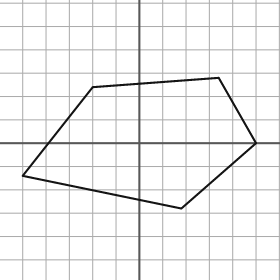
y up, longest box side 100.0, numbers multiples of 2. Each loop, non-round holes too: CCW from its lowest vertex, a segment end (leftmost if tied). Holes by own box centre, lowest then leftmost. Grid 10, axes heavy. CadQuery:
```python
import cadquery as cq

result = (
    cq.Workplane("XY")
    .moveTo(18.0, -28.0)
    .lineTo(50.0, 0.0)
    .lineTo(34.0, 28.0)
    .lineTo(-20.0, 24.0)
    .lineTo(-50.0, -14.0)
    .close()
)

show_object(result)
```